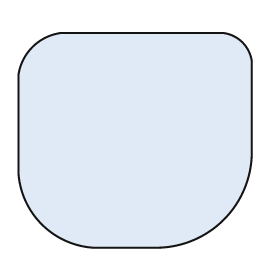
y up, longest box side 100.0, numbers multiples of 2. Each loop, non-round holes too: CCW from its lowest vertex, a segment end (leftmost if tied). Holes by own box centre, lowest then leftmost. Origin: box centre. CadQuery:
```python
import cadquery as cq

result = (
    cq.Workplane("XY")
    .moveTo(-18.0, -46.0)
    .lineTo(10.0, -46.0)
    .threePointArc((38.0, -34.0), (50.0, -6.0))
    .lineTo(50.0, 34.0)
    .threePointArc((46.0, 42.0), (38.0, 46.0))
    .lineTo(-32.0, 46.0)
    .threePointArc((-44.0, 40.0), (-50.0, 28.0))
    .lineTo(-50.0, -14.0)
    .threePointArc((-40.0, -36.0), (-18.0, -46.0))
    .close()
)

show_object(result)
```